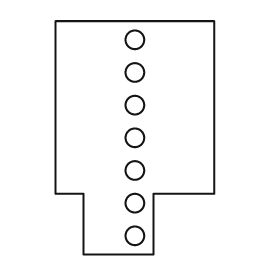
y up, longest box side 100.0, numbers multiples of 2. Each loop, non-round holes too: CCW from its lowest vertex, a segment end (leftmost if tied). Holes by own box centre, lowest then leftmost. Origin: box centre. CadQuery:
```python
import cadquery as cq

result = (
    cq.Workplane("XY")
    .moveTo(-22.0, -50.0)
    .lineTo(8.0, -50.0)
    .lineTo(8.0, -24.0)
    .lineTo(34.0, -24.0)
    .lineTo(34.0, 50.0)
    .lineTo(-34.0, 50.0)
    .lineTo(-34.0, -24.0)
    .lineTo(-22.0, -24.0)
    .close()
    .moveTo(0.0, -42.0)
    .circle(4.0)
    .moveTo(0.0, -28.0)
    .circle(4.0)
    .moveTo(0.0, -14.0)
    .circle(4.0)
    .moveTo(0.0, 0.0)
    .circle(4.0)
    .moveTo(0.0, 14.0)
    .circle(4.0)
    .moveTo(0.0, 28.0)
    .circle(4.0)
    .moveTo(0.0, 42.0)
    .circle(4.0)
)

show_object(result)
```